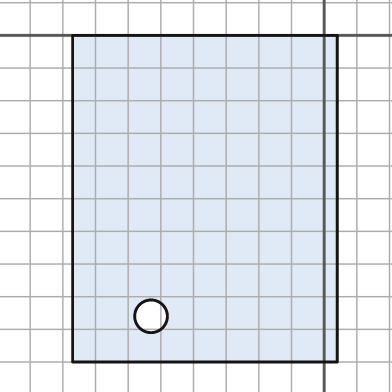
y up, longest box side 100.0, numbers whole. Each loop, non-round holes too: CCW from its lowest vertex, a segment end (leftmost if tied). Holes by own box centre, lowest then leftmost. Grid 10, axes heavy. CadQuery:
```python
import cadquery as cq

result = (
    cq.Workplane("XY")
    .moveTo(-77.0, -100.0)
    .lineTo(4.0, -100.0)
    .lineTo(4.0, 0.0)
    .lineTo(-77.0, 0.0)
    .close()
    .moveTo(-53.0, -86.0)
    .circle(5.0)
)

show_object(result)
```